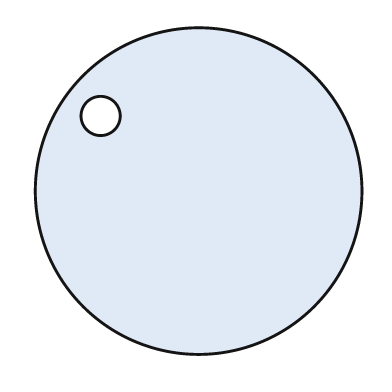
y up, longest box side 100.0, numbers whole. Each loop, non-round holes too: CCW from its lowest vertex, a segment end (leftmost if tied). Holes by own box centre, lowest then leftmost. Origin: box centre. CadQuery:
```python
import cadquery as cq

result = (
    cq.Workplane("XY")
    .moveTo(0.0, 0.0)
    .circle(50.0)
    .moveTo(-30.0, 23.0)
    .circle(6.0)
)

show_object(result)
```